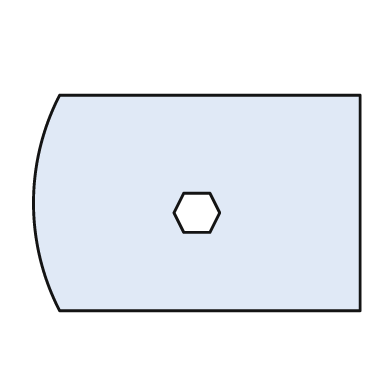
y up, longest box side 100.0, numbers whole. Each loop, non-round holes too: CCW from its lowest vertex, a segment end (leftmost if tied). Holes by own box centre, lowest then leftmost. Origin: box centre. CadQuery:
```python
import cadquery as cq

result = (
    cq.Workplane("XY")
    .moveTo(-42.0, -33.0)
    .lineTo(50.0, -33.0)
    .lineTo(50.0, 33.0)
    .lineTo(-42.0, 33.0)
    .threePointArc((-50.0, 0.0), (-42.0, -33.0))
    .close()
    .moveTo(-4.0, -9.0)
    .lineTo(4.0, -9.0)
    .lineTo(7.0, -3.0)
    .lineTo(4.0, 3.0)
    .lineTo(-4.0, 3.0)
    .lineTo(-7.0, -3.0)
    .close()
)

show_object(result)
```